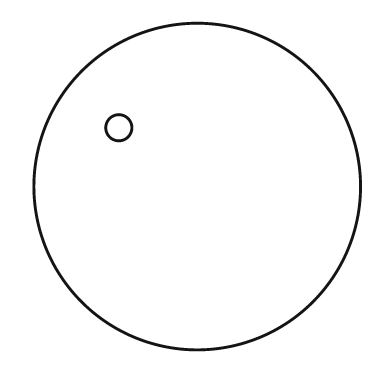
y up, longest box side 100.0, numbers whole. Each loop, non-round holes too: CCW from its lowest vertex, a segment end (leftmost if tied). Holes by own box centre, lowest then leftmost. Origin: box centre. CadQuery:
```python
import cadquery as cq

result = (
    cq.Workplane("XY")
    .moveTo(0.0, 0.0)
    .circle(50.0)
    .moveTo(-24.0, 18.0)
    .circle(4.0)
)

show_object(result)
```